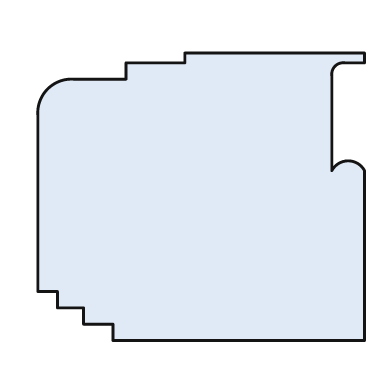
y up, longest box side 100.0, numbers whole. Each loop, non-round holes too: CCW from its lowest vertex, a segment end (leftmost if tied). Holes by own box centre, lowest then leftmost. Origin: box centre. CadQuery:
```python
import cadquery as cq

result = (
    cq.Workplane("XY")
    .moveTo(-27.0, -44.0)
    .lineTo(50.0, -44.0)
    .lineTo(50.0, 8.0)
    .threePointArc((45.0, 11.0), (40.0, 8.0))
    .lineTo(40.0, 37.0)
    .threePointArc((41.0, 40.0), (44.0, 41.0))
    .lineTo(50.0, 41.0)
    .lineTo(50.0, 44.0)
    .lineTo(-5.0, 44.0)
    .lineTo(-5.0, 41.0)
    .lineTo(-23.0, 41.0)
    .lineTo(-23.0, 36.0)
    .lineTo(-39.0, 36.0)
    .threePointArc((-47.0, 33.0), (-50.0, 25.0))
    .lineTo(-50.0, -29.0)
    .lineTo(-44.0, -29.0)
    .lineTo(-44.0, -34.0)
    .lineTo(-36.0, -34.0)
    .lineTo(-36.0, -39.0)
    .lineTo(-27.0, -39.0)
    .close()
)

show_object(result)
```